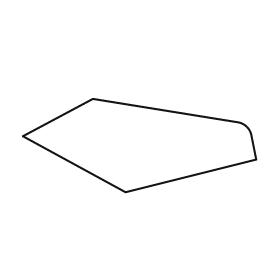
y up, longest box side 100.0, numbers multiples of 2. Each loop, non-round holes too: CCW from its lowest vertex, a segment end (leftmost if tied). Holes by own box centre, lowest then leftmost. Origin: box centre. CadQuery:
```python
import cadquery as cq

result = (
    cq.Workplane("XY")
    .moveTo(-6.0, -20.0)
    .lineTo(50.0, -6.0)
    .lineTo(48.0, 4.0)
    .threePointArc((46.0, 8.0), (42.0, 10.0))
    .lineTo(-20.0, 20.0)
    .lineTo(-50.0, 4.0)
    .close()
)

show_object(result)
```